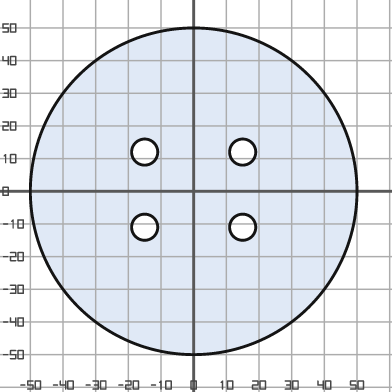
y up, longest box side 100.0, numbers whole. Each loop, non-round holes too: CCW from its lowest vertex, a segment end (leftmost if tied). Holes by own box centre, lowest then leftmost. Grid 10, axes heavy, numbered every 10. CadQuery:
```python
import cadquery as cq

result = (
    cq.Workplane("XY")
    .moveTo(0.0, 0.0)
    .circle(50.0)
    .moveTo(-15.0, -11.0)
    .circle(4.0)
    .moveTo(15.0, -11.0)
    .circle(4.0)
    .moveTo(-15.0, 12.0)
    .circle(4.0)
    .moveTo(15.0, 12.0)
    .circle(4.0)
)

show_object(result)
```